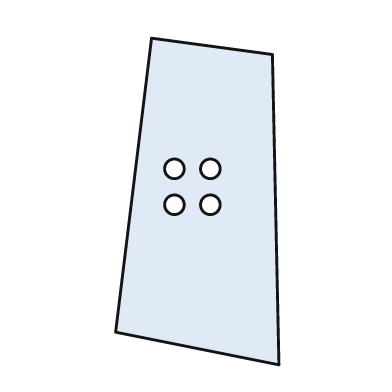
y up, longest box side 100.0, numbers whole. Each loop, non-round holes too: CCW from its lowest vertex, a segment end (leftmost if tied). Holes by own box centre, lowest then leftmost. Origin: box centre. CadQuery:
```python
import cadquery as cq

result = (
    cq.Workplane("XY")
    .moveTo(25.0, -50.0)
    .lineTo(23.0, 45.0)
    .lineTo(-14.0, 50.0)
    .lineTo(-25.0, -40.0)
    .close()
    .moveTo(-7.0, -1.0)
    .circle(3.0)
    .moveTo(4.0, -1.0)
    .circle(3.0)
    .moveTo(-7.0, 10.0)
    .circle(3.0)
    .moveTo(4.0, 10.0)
    .circle(3.0)
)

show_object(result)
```